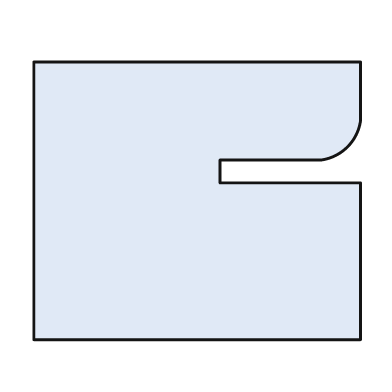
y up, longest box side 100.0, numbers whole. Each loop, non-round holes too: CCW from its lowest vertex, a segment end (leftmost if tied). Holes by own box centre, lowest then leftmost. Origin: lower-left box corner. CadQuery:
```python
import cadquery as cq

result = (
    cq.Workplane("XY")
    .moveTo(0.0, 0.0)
    .lineTo(100.0, 0.0)
    .lineTo(100.0, 48.0)
    .lineTo(57.0, 48.0)
    .lineTo(57.0, 55.0)
    .lineTo(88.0, 55.0)
    .threePointArc((96.0, 59.0), (100.0, 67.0))
    .lineTo(100.0, 85.0)
    .lineTo(0.0, 85.0)
    .close()
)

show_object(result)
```